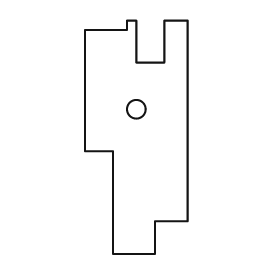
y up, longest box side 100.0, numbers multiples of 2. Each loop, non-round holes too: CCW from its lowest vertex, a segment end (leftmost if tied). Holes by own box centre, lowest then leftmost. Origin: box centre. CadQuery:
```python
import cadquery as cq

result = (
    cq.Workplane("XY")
    .moveTo(-10.0, -50.0)
    .lineTo(8.0, -50.0)
    .lineTo(8.0, -36.0)
    .lineTo(22.0, -36.0)
    .lineTo(22.0, 50.0)
    .lineTo(12.0, 50.0)
    .lineTo(12.0, 32.0)
    .lineTo(0.0, 32.0)
    .lineTo(0.0, 50.0)
    .lineTo(-4.0, 50.0)
    .lineTo(-4.0, 46.0)
    .lineTo(-22.0, 46.0)
    .lineTo(-22.0, -6.0)
    .lineTo(-10.0, -6.0)
    .close()
    .moveTo(0.0, 12.0)
    .circle(4.0)
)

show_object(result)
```